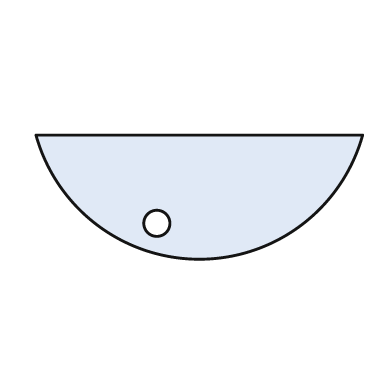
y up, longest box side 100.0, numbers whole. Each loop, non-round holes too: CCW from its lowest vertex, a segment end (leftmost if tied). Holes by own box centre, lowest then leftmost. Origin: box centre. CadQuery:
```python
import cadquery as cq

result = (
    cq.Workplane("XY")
    .moveTo(-50.0, 19.0)
    .threePointArc((0.0, -19.0), (50.0, 19.0))
    .close()
    .moveTo(-13.0, -8.0)
    .circle(4.0)
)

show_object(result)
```